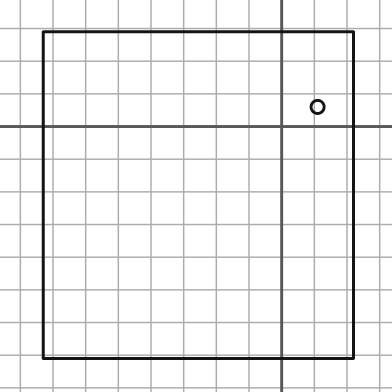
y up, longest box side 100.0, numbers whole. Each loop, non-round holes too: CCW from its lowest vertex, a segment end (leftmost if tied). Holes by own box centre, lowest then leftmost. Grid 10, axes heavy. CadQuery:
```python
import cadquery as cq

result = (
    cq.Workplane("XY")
    .moveTo(-73.0, -71.0)
    .lineTo(22.0, -71.0)
    .lineTo(22.0, 29.0)
    .lineTo(-73.0, 29.0)
    .close()
    .moveTo(11.0, 6.0)
    .circle(2.0)
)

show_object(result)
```